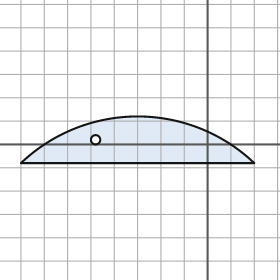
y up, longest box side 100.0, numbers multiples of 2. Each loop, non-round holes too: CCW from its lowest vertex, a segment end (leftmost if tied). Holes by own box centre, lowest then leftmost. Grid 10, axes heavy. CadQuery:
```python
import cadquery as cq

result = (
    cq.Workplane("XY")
    .moveTo(-80.0, -8.0)
    .lineTo(20.0, -8.0)
    .threePointArc((-30.0, 12.0), (-80.0, -8.0))
    .close()
    .moveTo(-48.0, 2.0)
    .circle(2.0)
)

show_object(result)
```